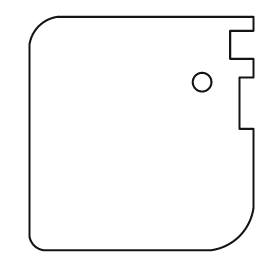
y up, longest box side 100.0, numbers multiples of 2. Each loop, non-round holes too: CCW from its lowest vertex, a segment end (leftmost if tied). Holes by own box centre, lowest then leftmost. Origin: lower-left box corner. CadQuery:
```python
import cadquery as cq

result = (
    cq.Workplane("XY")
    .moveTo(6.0, 0.0)
    .lineTo(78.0, 0.0)
    .threePointArc((90.0, 6.0), (96.0, 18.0))
    .lineTo(96.0, 52.0)
    .lineTo(90.0, 52.0)
    .lineTo(90.0, 74.0)
    .lineTo(96.0, 74.0)
    .lineTo(96.0, 82.0)
    .lineTo(86.0, 82.0)
    .lineTo(86.0, 94.0)
    .lineTo(96.0, 94.0)
    .lineTo(96.0, 100.0)
    .lineTo(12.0, 100.0)
    .threePointArc((4.0, 96.0), (0.0, 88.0))
    .lineTo(0.0, 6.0)
    .threePointArc((2.0, 2.0), (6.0, 0.0))
    .close()
    .moveTo(74.0, 72.0)
    .circle(4.0)
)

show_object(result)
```